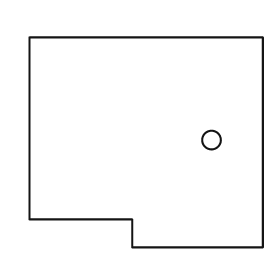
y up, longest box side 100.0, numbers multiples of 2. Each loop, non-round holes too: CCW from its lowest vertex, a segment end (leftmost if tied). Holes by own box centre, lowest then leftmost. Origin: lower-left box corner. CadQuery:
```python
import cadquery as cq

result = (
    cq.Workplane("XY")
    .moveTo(44.0, 0.0)
    .lineTo(100.0, 0.0)
    .lineTo(100.0, 90.0)
    .lineTo(0.0, 90.0)
    .lineTo(0.0, 12.0)
    .lineTo(44.0, 12.0)
    .close()
    .moveTo(78.0, 46.0)
    .circle(4.0)
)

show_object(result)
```